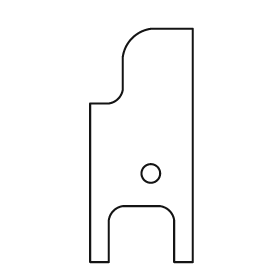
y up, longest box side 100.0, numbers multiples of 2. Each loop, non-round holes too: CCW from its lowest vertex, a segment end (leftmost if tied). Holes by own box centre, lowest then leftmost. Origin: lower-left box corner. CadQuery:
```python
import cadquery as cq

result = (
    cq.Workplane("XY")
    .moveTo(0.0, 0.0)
    .lineTo(8.0, 0.0)
    .lineTo(8.0, 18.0)
    .threePointArc((10.0, 22.0), (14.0, 24.0))
    .lineTo(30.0, 24.0)
    .threePointArc((34.0, 22.0), (36.0, 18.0))
    .lineTo(36.0, 0.0)
    .lineTo(44.0, 0.0)
    .lineTo(44.0, 100.0)
    .lineTo(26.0, 100.0)
    .threePointArc((18.0, 96.0), (14.0, 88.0))
    .lineTo(14.0, 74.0)
    .threePointArc((12.0, 70.0), (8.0, 68.0))
    .lineTo(0.0, 68.0)
    .close()
    .moveTo(26.0, 38.0)
    .circle(4.0)
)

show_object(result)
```